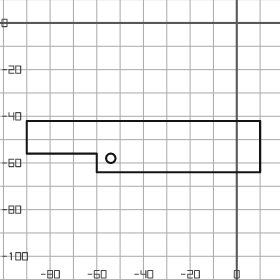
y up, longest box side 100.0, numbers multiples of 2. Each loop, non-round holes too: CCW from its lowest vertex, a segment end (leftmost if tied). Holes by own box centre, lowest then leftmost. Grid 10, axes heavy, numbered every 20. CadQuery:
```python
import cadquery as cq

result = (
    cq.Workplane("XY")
    .moveTo(-60.0, -64.0)
    .lineTo(10.0, -64.0)
    .lineTo(10.0, -42.0)
    .lineTo(-90.0, -42.0)
    .lineTo(-90.0, -56.0)
    .lineTo(-60.0, -56.0)
    .close()
    .moveTo(-54.0, -58.0)
    .circle(2.0)
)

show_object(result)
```